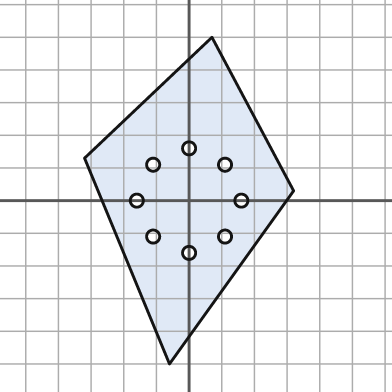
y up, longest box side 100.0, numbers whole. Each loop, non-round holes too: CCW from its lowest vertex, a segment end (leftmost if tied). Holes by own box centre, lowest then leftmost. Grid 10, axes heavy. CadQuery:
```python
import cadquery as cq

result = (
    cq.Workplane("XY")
    .moveTo(-6.0, -50.0)
    .lineTo(32.0, 3.0)
    .lineTo(7.0, 50.0)
    .lineTo(-32.0, 13.0)
    .close()
    .moveTo(0.0, -16.0)
    .circle(2.0)
    .moveTo(-11.0, -11.0)
    .circle(2.0)
    .moveTo(11.0, -11.0)
    .circle(2.0)
    .moveTo(-16.0, 0.0)
    .circle(2.0)
    .moveTo(16.0, 0.0)
    .circle(2.0)
    .moveTo(-11.0, 11.0)
    .circle(2.0)
    .moveTo(11.0, 11.0)
    .circle(2.0)
    .moveTo(0.0, 16.0)
    .circle(2.0)
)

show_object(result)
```